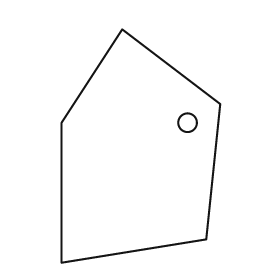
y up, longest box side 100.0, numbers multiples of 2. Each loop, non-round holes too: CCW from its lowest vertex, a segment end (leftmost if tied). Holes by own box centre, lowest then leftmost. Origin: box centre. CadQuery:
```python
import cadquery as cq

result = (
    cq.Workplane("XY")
    .moveTo(-34.0, -50.0)
    .lineTo(28.0, -40.0)
    .lineTo(34.0, 18.0)
    .lineTo(-8.0, 50.0)
    .lineTo(-34.0, 10.0)
    .close()
    .moveTo(20.0, 10.0)
    .circle(4.0)
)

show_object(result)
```